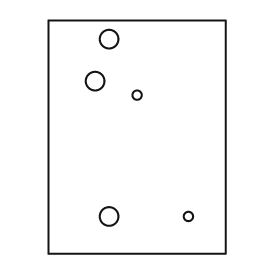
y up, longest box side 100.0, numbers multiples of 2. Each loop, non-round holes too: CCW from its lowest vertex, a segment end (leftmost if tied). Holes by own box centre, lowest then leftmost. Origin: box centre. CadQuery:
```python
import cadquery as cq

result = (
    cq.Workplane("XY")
    .moveTo(-38.0, -50.0)
    .lineTo(38.0, -50.0)
    .lineTo(38.0, 50.0)
    .lineTo(-38.0, 50.0)
    .close()
    .moveTo(-12.0, -34.0)
    .circle(4.0)
    .moveTo(22.0, -34.0)
    .circle(2.0)
    .moveTo(0.0, 18.0)
    .circle(2.0)
    .moveTo(-18.0, 24.0)
    .circle(4.0)
    .moveTo(-12.0, 42.0)
    .circle(4.0)
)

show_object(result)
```